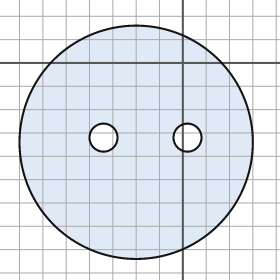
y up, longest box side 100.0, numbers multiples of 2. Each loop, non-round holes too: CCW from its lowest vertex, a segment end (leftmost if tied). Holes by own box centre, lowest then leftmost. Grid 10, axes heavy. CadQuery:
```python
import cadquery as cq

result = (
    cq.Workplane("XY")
    .moveTo(-20.0, -34.0)
    .circle(50.0)
    .moveTo(-34.0, -32.0)
    .circle(6.0)
    .moveTo(2.0, -32.0)
    .circle(6.0)
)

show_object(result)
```